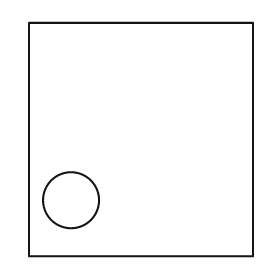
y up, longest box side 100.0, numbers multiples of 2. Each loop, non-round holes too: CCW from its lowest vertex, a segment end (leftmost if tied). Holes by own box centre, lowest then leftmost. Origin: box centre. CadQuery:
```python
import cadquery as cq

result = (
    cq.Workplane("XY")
    .moveTo(-48.0, -50.0)
    .lineTo(48.0, -50.0)
    .lineTo(48.0, 50.0)
    .lineTo(-48.0, 50.0)
    .close()
    .moveTo(-30.0, -26.0)
    .circle(12.0)
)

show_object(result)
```